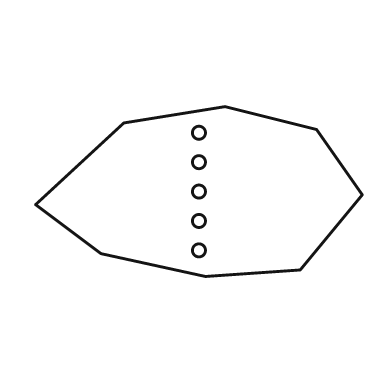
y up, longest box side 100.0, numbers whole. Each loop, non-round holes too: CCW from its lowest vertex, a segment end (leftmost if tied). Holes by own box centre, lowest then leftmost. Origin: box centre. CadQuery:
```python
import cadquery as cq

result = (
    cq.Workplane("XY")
    .moveTo(2.0, -26.0)
    .lineTo(31.0, -24.0)
    .lineTo(50.0, -1.0)
    .lineTo(36.0, 19.0)
    .lineTo(8.0, 26.0)
    .lineTo(-23.0, 21.0)
    .lineTo(-50.0, -4.0)
    .lineTo(-30.0, -19.0)
    .close()
    .moveTo(0.0, -18.0)
    .circle(2.0)
    .moveTo(0.0, -9.0)
    .circle(2.0)
    .moveTo(0.0, 0.0)
    .circle(2.0)
    .moveTo(0.0, 9.0)
    .circle(2.0)
    .moveTo(0.0, 18.0)
    .circle(2.0)
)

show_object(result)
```